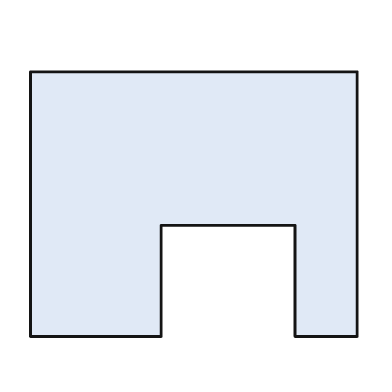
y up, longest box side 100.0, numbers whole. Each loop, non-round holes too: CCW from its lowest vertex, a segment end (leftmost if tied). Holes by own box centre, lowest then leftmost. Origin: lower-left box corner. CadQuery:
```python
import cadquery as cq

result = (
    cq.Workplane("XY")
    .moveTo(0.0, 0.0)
    .lineTo(40.0, 0.0)
    .lineTo(40.0, 34.0)
    .lineTo(81.0, 34.0)
    .lineTo(81.0, 0.0)
    .lineTo(100.0, 0.0)
    .lineTo(100.0, 81.0)
    .lineTo(0.0, 81.0)
    .close()
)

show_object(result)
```